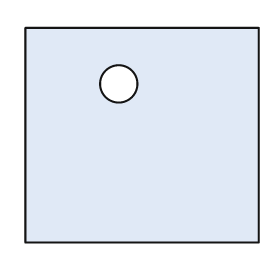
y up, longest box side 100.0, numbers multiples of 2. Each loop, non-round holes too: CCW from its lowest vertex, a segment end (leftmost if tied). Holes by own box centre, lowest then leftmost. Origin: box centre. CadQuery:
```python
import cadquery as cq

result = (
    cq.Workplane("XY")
    .moveTo(-50.0, -46.0)
    .lineTo(50.0, -46.0)
    .lineTo(50.0, 46.0)
    .lineTo(-50.0, 46.0)
    .close()
    .moveTo(-10.0, 22.0)
    .circle(8.0)
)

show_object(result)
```